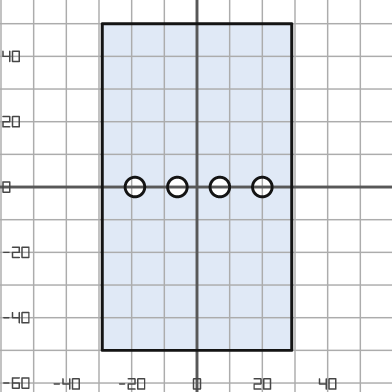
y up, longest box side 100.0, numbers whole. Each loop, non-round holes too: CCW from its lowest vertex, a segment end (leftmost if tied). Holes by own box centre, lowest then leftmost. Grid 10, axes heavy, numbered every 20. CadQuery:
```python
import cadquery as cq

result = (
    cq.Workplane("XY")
    .moveTo(-29.0, -50.0)
    .lineTo(29.0, -50.0)
    .lineTo(29.0, 50.0)
    .lineTo(-29.0, 50.0)
    .close()
    .moveTo(-19.0, 0.0)
    .circle(3.0)
    .moveTo(-6.0, 0.0)
    .circle(3.0)
    .moveTo(7.0, 0.0)
    .circle(3.0)
    .moveTo(20.0, 0.0)
    .circle(3.0)
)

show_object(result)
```